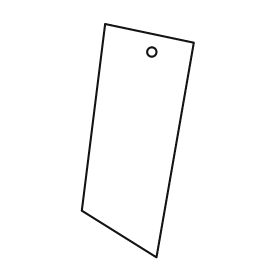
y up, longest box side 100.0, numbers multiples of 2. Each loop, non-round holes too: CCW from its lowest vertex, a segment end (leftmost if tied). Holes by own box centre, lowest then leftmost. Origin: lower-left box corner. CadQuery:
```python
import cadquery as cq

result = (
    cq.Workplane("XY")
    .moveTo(32.0, 0.0)
    .lineTo(48.0, 92.0)
    .lineTo(10.0, 100.0)
    .lineTo(0.0, 20.0)
    .close()
    .moveTo(30.0, 88.0)
    .circle(2.0)
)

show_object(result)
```